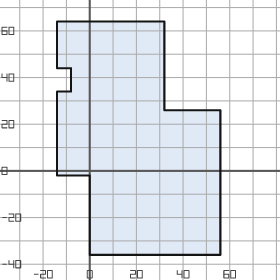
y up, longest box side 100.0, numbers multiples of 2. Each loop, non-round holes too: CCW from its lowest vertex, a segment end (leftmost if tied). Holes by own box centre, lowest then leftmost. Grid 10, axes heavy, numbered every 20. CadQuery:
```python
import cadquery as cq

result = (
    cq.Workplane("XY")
    .moveTo(0.0, -36.0)
    .lineTo(56.0, -36.0)
    .lineTo(56.0, 26.0)
    .lineTo(32.0, 26.0)
    .lineTo(32.0, 64.0)
    .lineTo(-14.0, 64.0)
    .lineTo(-14.0, 44.0)
    .lineTo(-8.0, 44.0)
    .lineTo(-8.0, 34.0)
    .lineTo(-14.0, 34.0)
    .lineTo(-14.0, -2.0)
    .lineTo(0.0, -2.0)
    .close()
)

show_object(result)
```